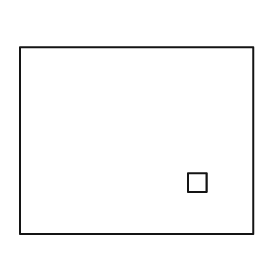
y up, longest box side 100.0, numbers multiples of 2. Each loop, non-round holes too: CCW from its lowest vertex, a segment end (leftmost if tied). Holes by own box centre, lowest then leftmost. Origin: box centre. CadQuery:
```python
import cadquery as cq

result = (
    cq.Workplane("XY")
    .moveTo(-50.0, -40.0)
    .lineTo(50.0, -40.0)
    .lineTo(50.0, 40.0)
    .lineTo(-50.0, 40.0)
    .close()
    .moveTo(22.0, -22.0)
    .lineTo(30.0, -22.0)
    .lineTo(30.0, -14.0)
    .lineTo(22.0, -14.0)
    .close()
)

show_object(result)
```